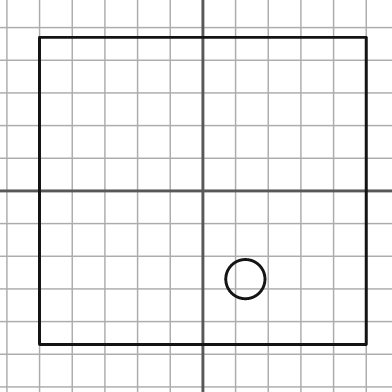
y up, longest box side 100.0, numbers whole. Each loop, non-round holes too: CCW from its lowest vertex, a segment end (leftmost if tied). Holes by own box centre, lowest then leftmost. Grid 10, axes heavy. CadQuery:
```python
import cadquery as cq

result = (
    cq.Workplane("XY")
    .moveTo(-50.0, -47.0)
    .lineTo(50.0, -47.0)
    .lineTo(50.0, 47.0)
    .lineTo(-50.0, 47.0)
    .close()
    .moveTo(13.0, -27.0)
    .circle(6.0)
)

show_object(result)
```